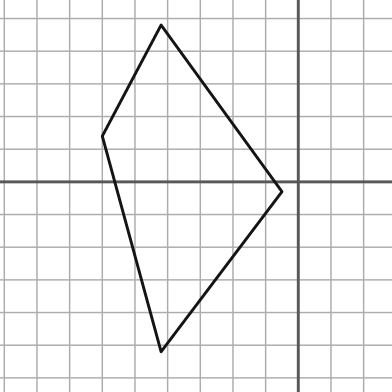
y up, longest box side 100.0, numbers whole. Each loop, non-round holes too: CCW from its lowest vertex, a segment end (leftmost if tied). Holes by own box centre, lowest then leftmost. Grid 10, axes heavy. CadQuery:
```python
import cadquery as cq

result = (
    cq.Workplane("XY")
    .moveTo(-42.0, -52.0)
    .lineTo(-5.0, -3.0)
    .lineTo(-42.0, 48.0)
    .lineTo(-60.0, 14.0)
    .close()
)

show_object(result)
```